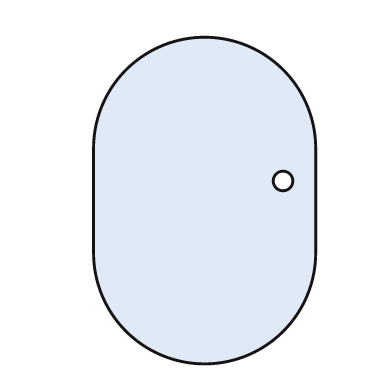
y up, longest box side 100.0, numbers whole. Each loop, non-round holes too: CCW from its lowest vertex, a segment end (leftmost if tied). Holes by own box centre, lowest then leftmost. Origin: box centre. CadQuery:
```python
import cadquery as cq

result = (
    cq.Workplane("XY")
    .moveTo(-34.0, -16.0)
    .threePointArc((0.0, -50.0), (34.0, -16.0))
    .lineTo(34.0, 16.0)
    .threePointArc((0.0, 50.0), (-34.0, 16.0))
    .close()
    .moveTo(24.0, 6.0)
    .circle(3.0)
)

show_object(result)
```